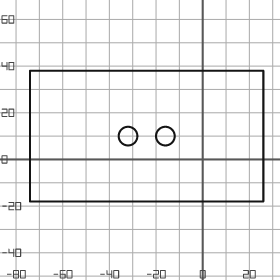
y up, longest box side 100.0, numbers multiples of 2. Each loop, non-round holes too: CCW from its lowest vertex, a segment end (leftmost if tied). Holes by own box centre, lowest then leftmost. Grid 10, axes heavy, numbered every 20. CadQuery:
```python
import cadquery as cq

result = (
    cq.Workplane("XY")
    .moveTo(-74.0, -18.0)
    .lineTo(26.0, -18.0)
    .lineTo(26.0, 38.0)
    .lineTo(-74.0, 38.0)
    .close()
    .moveTo(-32.0, 10.0)
    .circle(4.0)
    .moveTo(-16.0, 10.0)
    .circle(4.0)
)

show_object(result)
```